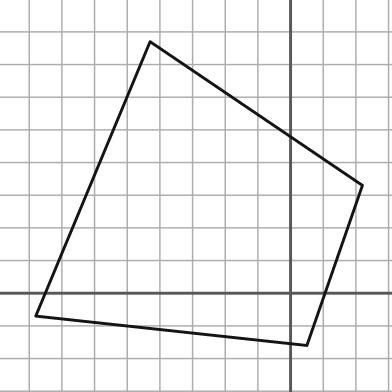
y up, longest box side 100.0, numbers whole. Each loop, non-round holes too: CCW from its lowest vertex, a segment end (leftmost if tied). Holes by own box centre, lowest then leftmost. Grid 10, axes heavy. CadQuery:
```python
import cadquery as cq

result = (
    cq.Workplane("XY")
    .moveTo(5.0, -16.0)
    .lineTo(22.0, 33.0)
    .lineTo(-43.0, 77.0)
    .lineTo(-78.0, -7.0)
    .close()
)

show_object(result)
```